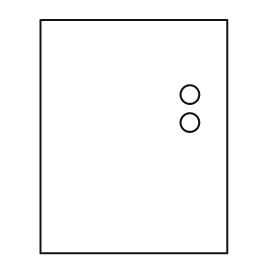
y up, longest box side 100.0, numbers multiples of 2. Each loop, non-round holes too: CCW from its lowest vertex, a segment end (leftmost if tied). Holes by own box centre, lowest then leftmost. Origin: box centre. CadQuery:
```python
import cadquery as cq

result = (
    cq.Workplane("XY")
    .moveTo(-40.0, -50.0)
    .lineTo(40.0, -50.0)
    .lineTo(40.0, 50.0)
    .lineTo(-40.0, 50.0)
    .close()
    .moveTo(24.0, 6.0)
    .circle(4.0)
    .moveTo(24.0, 18.0)
    .circle(4.0)
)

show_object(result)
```